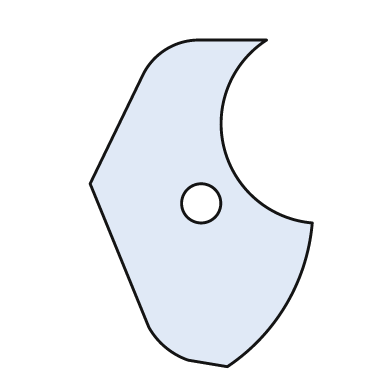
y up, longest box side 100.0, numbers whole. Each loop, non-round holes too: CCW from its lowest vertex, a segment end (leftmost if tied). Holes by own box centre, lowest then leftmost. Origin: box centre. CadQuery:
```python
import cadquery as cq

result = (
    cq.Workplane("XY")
    .moveTo(8.0, -50.0)
    .threePointArc((26.0, -31.0), (34.0, -6.0))
    .threePointArc((7.0, 17.0), (20.0, 50.0))
    .lineTo(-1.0, 50.0)
    .threePointArc((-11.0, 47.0), (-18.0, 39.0))
    .lineTo(-34.0, 6.0)
    .lineTo(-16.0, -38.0)
    .threePointArc((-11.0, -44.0), (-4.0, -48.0))
    .close()
    .moveTo(0.0, 0.0)
    .circle(6.0)
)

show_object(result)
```